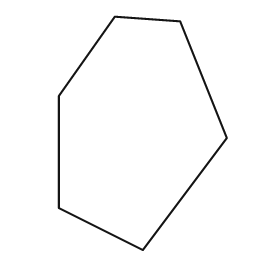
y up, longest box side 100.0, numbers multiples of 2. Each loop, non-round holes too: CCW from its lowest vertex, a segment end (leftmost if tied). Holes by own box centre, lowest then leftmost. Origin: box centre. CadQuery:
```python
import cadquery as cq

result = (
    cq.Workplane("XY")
    .moveTo(0.0, -50.0)
    .lineTo(36.0, -2.0)
    .lineTo(16.0, 48.0)
    .lineTo(-12.0, 50.0)
    .lineTo(-36.0, 16.0)
    .lineTo(-36.0, -32.0)
    .close()
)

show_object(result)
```